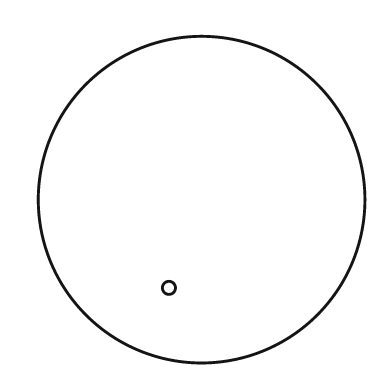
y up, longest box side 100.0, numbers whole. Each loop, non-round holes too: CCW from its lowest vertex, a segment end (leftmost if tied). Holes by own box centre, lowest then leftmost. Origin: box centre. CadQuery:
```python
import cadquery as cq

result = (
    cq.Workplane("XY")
    .moveTo(0.0, 0.0)
    .circle(50.0)
    .moveTo(-10.0, -27.0)
    .circle(2.0)
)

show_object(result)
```